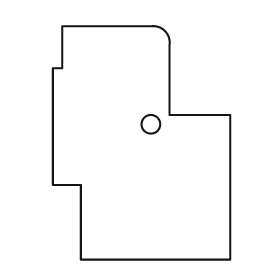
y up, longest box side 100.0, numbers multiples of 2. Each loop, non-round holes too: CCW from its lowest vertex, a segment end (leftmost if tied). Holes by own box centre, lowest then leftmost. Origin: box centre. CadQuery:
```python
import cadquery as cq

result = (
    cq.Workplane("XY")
    .moveTo(-26.0, -50.0)
    .lineTo(38.0, -50.0)
    .lineTo(38.0, 12.0)
    .lineTo(12.0, 12.0)
    .lineTo(12.0, 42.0)
    .threePointArc((10.0, 48.0), (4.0, 50.0))
    .lineTo(-34.0, 50.0)
    .lineTo(-34.0, 32.0)
    .lineTo(-38.0, 32.0)
    .lineTo(-38.0, -18.0)
    .lineTo(-26.0, -18.0)
    .close()
    .moveTo(4.0, 8.0)
    .circle(4.0)
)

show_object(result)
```